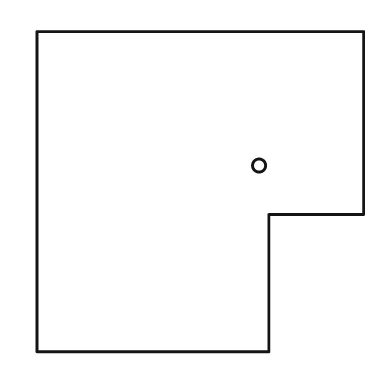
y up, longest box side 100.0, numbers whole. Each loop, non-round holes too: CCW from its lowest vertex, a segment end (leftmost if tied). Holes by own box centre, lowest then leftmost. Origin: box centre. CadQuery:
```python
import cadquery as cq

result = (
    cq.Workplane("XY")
    .moveTo(-50.0, -49.0)
    .lineTo(21.0, -49.0)
    .lineTo(21.0, -7.0)
    .lineTo(50.0, -7.0)
    .lineTo(50.0, 49.0)
    .lineTo(-50.0, 49.0)
    .close()
    .moveTo(18.0, 8.0)
    .circle(2.0)
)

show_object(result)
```